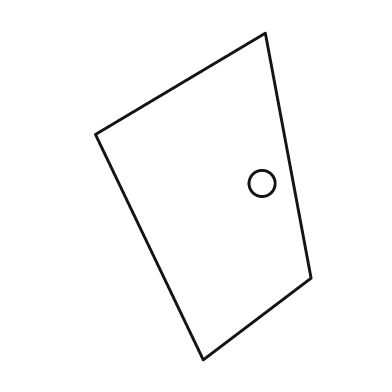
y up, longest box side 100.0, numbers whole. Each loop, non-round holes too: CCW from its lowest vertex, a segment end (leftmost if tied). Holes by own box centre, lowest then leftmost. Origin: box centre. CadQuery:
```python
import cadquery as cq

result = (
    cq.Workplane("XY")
    .moveTo(0.0, -50.0)
    .lineTo(33.0, -25.0)
    .lineTo(19.0, 50.0)
    .lineTo(-33.0, 19.0)
    .close()
    .moveTo(18.0, 4.0)
    .circle(4.0)
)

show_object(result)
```